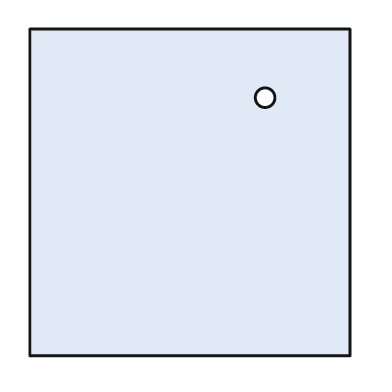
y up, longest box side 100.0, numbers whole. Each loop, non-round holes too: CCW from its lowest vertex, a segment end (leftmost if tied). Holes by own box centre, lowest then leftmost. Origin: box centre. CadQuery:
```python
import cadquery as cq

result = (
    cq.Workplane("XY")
    .moveTo(-49.0, -50.0)
    .lineTo(49.0, -50.0)
    .lineTo(49.0, 50.0)
    .lineTo(-49.0, 50.0)
    .close()
    .moveTo(23.0, 29.0)
    .circle(3.0)
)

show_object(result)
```